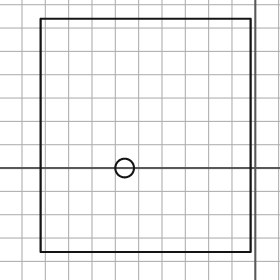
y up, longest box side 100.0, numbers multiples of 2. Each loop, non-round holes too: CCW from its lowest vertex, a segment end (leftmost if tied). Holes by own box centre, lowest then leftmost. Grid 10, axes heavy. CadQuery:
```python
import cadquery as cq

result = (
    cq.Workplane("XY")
    .moveTo(-92.0, -36.0)
    .lineTo(-2.0, -36.0)
    .lineTo(-2.0, 64.0)
    .lineTo(-92.0, 64.0)
    .close()
    .moveTo(-56.0, 0.0)
    .circle(4.0)
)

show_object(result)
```